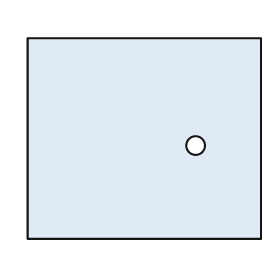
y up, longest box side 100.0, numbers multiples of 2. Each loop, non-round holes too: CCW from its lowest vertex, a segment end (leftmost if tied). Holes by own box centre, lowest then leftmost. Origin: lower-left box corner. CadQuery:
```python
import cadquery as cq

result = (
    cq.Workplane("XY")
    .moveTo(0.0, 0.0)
    .lineTo(100.0, 0.0)
    .lineTo(100.0, 86.0)
    .lineTo(0.0, 86.0)
    .close()
    .moveTo(72.0, 40.0)
    .circle(4.0)
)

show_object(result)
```